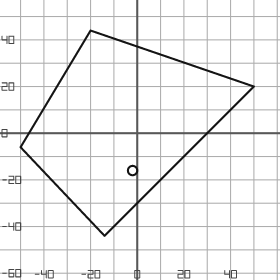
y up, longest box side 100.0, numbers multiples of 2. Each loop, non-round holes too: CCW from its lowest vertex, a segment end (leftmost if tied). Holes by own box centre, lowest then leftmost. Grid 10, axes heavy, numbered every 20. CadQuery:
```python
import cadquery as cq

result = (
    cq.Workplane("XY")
    .moveTo(-14.0, -44.0)
    .lineTo(50.0, 20.0)
    .lineTo(-20.0, 44.0)
    .lineTo(-50.0, -6.0)
    .close()
    .moveTo(-2.0, -16.0)
    .circle(2.0)
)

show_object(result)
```